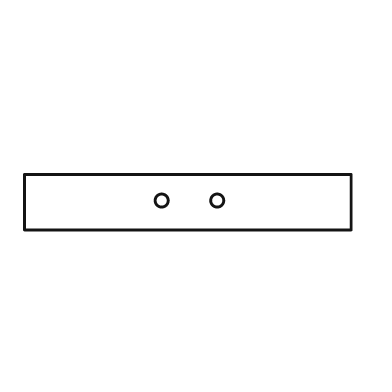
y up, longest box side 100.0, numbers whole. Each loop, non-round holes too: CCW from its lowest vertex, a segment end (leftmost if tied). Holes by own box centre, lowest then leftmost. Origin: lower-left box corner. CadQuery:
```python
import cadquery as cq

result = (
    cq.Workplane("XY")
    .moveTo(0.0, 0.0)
    .lineTo(100.0, 0.0)
    .lineTo(100.0, 17.0)
    .lineTo(0.0, 17.0)
    .close()
    .moveTo(42.0, 9.0)
    .circle(2.0)
    .moveTo(59.0, 9.0)
    .circle(2.0)
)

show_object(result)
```